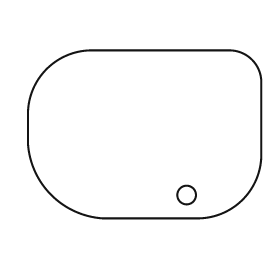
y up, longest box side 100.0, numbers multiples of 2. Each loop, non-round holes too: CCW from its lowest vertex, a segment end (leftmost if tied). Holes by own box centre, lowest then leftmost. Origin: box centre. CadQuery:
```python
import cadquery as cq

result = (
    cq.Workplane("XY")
    .moveTo(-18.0, -36.0)
    .lineTo(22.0, -36.0)
    .threePointArc((42.0, -28.0), (50.0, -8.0))
    .lineTo(50.0, 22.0)
    .threePointArc((46.0, 32.0), (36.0, 36.0))
    .lineTo(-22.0, 36.0)
    .threePointArc((-42.0, 28.0), (-50.0, 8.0))
    .lineTo(-50.0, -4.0)
    .threePointArc((-40.0, -26.0), (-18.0, -36.0))
    .close()
    .moveTo(18.0, -26.0)
    .circle(4.0)
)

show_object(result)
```